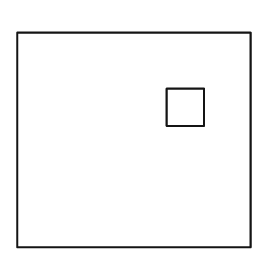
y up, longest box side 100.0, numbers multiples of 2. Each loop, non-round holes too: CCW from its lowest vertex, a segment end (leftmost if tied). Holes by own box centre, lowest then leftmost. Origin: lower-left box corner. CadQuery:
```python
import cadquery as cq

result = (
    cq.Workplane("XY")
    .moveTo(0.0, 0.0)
    .lineTo(100.0, 0.0)
    .lineTo(100.0, 92.0)
    .lineTo(0.0, 92.0)
    .close()
    .moveTo(64.0, 52.0)
    .lineTo(80.0, 52.0)
    .lineTo(80.0, 68.0)
    .lineTo(64.0, 68.0)
    .close()
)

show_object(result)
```